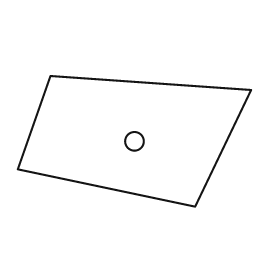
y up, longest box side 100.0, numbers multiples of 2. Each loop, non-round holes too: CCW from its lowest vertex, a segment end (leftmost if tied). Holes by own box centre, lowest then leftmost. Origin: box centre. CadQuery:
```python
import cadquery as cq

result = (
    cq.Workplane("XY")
    .moveTo(26.0, -28.0)
    .lineTo(50.0, 22.0)
    .lineTo(-36.0, 28.0)
    .lineTo(-50.0, -12.0)
    .close()
    .moveTo(0.0, 0.0)
    .circle(4.0)
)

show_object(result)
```